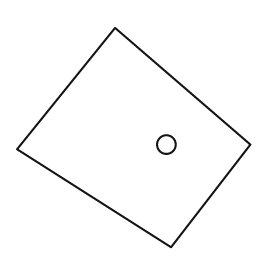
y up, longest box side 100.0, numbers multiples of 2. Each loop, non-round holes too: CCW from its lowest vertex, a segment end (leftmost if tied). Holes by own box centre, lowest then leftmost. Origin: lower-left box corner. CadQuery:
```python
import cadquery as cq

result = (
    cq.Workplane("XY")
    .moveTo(66.0, 0.0)
    .lineTo(100.0, 44.0)
    .lineTo(42.0, 94.0)
    .lineTo(0.0, 42.0)
    .close()
    .moveTo(64.0, 44.0)
    .circle(4.0)
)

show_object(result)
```